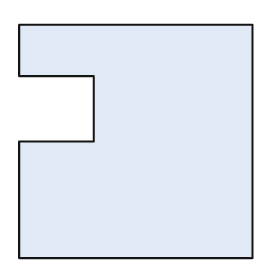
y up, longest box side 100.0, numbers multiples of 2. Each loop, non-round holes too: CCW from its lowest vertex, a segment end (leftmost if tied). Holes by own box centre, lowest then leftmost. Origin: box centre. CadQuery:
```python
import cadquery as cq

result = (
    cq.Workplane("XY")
    .moveTo(-50.0, -50.0)
    .lineTo(50.0, -50.0)
    .lineTo(50.0, 50.0)
    .lineTo(-50.0, 50.0)
    .lineTo(-50.0, 28.0)
    .lineTo(-18.0, 28.0)
    .lineTo(-18.0, 0.0)
    .lineTo(-50.0, 0.0)
    .close()
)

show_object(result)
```